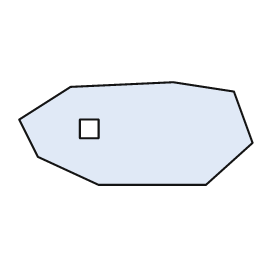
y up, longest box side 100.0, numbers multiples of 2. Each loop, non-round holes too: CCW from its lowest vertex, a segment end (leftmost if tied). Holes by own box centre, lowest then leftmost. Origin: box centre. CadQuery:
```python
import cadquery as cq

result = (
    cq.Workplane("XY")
    .moveTo(-16.0, -22.0)
    .lineTo(30.0, -22.0)
    .lineTo(50.0, -4.0)
    .lineTo(42.0, 18.0)
    .lineTo(16.0, 22.0)
    .lineTo(-28.0, 20.0)
    .lineTo(-50.0, 6.0)
    .lineTo(-42.0, -10.0)
    .close()
    .moveTo(-24.0, -2.0)
    .lineTo(-16.0, -2.0)
    .lineTo(-16.0, 6.0)
    .lineTo(-24.0, 6.0)
    .close()
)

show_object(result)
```